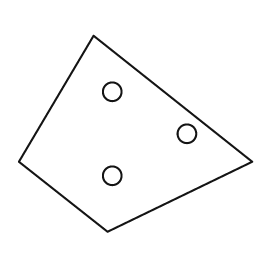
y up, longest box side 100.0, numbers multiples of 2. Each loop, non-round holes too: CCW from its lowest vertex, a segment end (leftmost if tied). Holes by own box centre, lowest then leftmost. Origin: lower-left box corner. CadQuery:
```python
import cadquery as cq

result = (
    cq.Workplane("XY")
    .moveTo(38.0, 0.0)
    .lineTo(100.0, 30.0)
    .lineTo(32.0, 84.0)
    .lineTo(0.0, 30.0)
    .close()
    .moveTo(40.0, 24.0)
    .circle(4.0)
    .moveTo(72.0, 42.0)
    .circle(4.0)
    .moveTo(40.0, 60.0)
    .circle(4.0)
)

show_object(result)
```